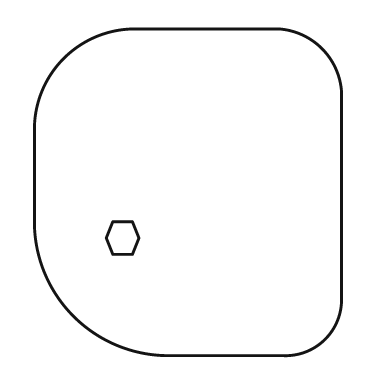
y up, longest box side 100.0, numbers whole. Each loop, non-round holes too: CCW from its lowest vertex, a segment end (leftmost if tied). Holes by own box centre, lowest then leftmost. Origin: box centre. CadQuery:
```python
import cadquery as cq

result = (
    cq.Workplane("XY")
    .moveTo(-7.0, -50.0)
    .lineTo(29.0, -50.0)
    .threePointArc((42.0, -45.0), (47.0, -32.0))
    .lineTo(47.0, 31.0)
    .threePointArc((41.0, 44.0), (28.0, 50.0))
    .lineTo(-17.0, 50.0)
    .threePointArc((-38.0, 41.0), (-47.0, 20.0))
    .lineTo(-47.0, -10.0)
    .threePointArc((-35.0, -38.0), (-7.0, -50.0))
    .close()
    .moveTo(-23.0, -19.0)
    .lineTo(-17.0, -19.0)
    .lineTo(-15.0, -14.0)
    .lineTo(-17.0, -9.0)
    .lineTo(-23.0, -9.0)
    .lineTo(-25.0, -14.0)
    .close()
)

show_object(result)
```